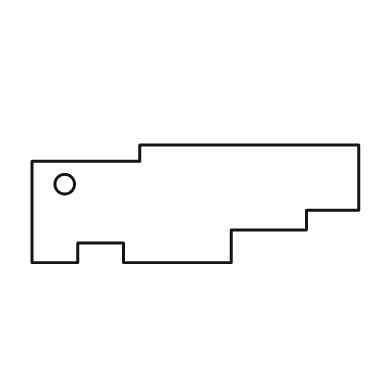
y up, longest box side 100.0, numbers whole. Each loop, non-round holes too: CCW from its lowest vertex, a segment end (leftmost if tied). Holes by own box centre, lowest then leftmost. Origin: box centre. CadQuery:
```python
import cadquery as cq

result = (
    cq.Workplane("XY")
    .moveTo(-50.0, -18.0)
    .lineTo(-36.0, -18.0)
    .lineTo(-36.0, -12.0)
    .lineTo(-22.0, -12.0)
    .lineTo(-22.0, -18.0)
    .lineTo(11.0, -18.0)
    .lineTo(11.0, -8.0)
    .lineTo(34.0, -8.0)
    .lineTo(34.0, -2.0)
    .lineTo(50.0, -2.0)
    .lineTo(50.0, 18.0)
    .lineTo(-17.0, 18.0)
    .lineTo(-17.0, 13.0)
    .lineTo(-50.0, 13.0)
    .close()
    .moveTo(-40.0, 6.0)
    .circle(3.0)
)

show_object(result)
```